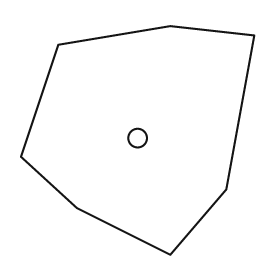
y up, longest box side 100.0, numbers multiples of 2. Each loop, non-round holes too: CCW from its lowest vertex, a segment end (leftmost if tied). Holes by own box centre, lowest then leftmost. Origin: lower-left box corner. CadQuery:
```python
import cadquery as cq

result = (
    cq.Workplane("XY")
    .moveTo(64.0, 0.0)
    .lineTo(88.0, 28.0)
    .lineTo(100.0, 94.0)
    .lineTo(64.0, 98.0)
    .lineTo(16.0, 90.0)
    .lineTo(0.0, 42.0)
    .lineTo(24.0, 20.0)
    .close()
    .moveTo(50.0, 50.0)
    .circle(4.0)
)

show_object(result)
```